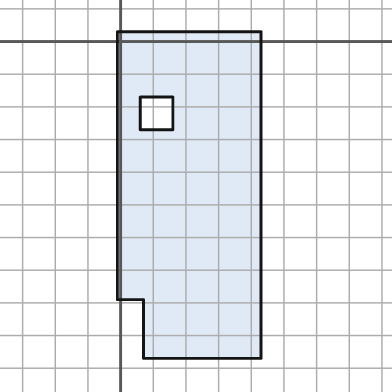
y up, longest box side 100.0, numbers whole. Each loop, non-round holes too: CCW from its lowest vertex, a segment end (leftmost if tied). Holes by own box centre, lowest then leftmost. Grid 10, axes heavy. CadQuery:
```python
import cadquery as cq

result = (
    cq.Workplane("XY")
    .moveTo(7.0, -97.0)
    .lineTo(43.0, -97.0)
    .lineTo(43.0, 3.0)
    .lineTo(-1.0, 3.0)
    .lineTo(-1.0, -79.0)
    .lineTo(7.0, -79.0)
    .close()
    .moveTo(6.0, -27.0)
    .lineTo(16.0, -27.0)
    .lineTo(16.0, -17.0)
    .lineTo(6.0, -17.0)
    .close()
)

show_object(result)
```